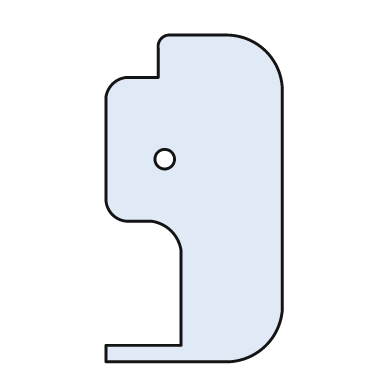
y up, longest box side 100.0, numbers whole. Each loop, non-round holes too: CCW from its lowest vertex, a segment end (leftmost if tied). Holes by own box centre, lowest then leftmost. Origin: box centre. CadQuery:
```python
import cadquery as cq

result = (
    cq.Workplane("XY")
    .moveTo(-27.0, -50.0)
    .lineTo(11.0, -50.0)
    .threePointArc((22.0, -45.0), (27.0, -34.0))
    .lineTo(27.0, 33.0)
    .threePointArc((22.0, 45.0), (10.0, 50.0))
    .lineTo(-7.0, 50.0)
    .threePointArc((-10.0, 49.0), (-11.0, 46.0))
    .lineTo(-11.0, 37.0)
    .lineTo(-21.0, 37.0)
    .threePointArc((-25.0, 35.0), (-27.0, 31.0))
    .lineTo(-27.0, 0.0)
    .threePointArc((-25.0, -5.0), (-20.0, -7.0))
    .lineTo(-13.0, -7.0)
    .threePointArc((-7.0, -10.0), (-4.0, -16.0))
    .lineTo(-4.0, -45.0)
    .lineTo(-27.0, -45.0)
    .close()
    .moveTo(-9.0, 12.0)
    .circle(3.0)
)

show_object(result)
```